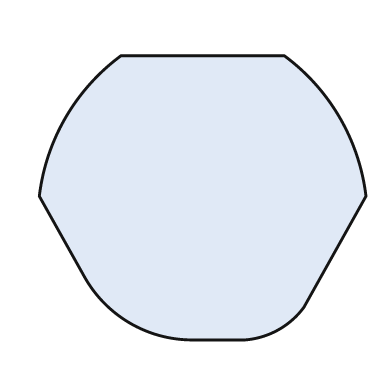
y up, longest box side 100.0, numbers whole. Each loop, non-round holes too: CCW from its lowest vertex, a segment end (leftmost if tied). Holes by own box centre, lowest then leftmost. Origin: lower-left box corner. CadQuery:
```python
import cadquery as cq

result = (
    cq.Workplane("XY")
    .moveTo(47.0, 0.0)
    .lineTo(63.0, 0.0)
    .threePointArc((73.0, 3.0), (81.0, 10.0))
    .lineTo(100.0, 44.0)
    .threePointArc((92.0, 68.0), (75.0, 87.0))
    .lineTo(25.0, 87.0)
    .threePointArc((8.0, 68.0), (0.0, 44.0))
    .lineTo(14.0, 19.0)
    .threePointArc((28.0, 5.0), (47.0, 0.0))
    .close()
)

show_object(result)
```